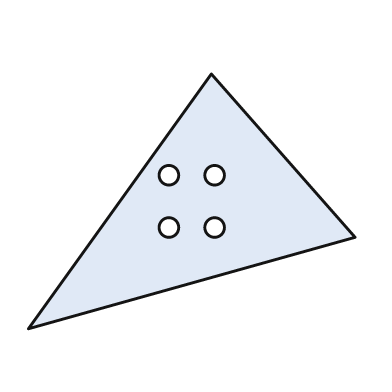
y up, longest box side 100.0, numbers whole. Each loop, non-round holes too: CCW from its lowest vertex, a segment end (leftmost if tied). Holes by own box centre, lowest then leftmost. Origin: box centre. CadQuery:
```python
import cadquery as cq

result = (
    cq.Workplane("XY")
    .moveTo(-50.0, -39.0)
    .lineTo(50.0, -11.0)
    .lineTo(6.0, 39.0)
    .close()
    .moveTo(-7.0, -8.0)
    .circle(3.0)
    .moveTo(7.0, -8.0)
    .circle(3.0)
    .moveTo(-7.0, 8.0)
    .circle(3.0)
    .moveTo(7.0, 8.0)
    .circle(3.0)
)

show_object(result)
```